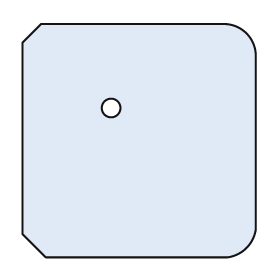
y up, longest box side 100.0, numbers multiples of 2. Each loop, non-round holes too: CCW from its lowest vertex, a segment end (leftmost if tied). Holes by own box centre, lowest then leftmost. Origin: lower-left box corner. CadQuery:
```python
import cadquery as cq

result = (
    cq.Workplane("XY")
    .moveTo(10.0, 0.0)
    .lineTo(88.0, 0.0)
    .threePointArc((96.0, 4.0), (100.0, 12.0))
    .lineTo(100.0, 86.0)
    .threePointArc((96.0, 96.0), (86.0, 100.0))
    .lineTo(8.0, 100.0)
    .lineTo(0.0, 92.0)
    .lineTo(0.0, 10.0)
    .close()
    .moveTo(38.0, 64.0)
    .circle(4.0)
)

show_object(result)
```